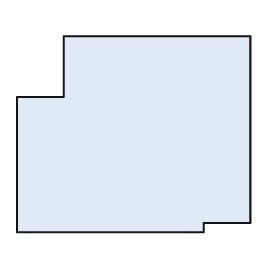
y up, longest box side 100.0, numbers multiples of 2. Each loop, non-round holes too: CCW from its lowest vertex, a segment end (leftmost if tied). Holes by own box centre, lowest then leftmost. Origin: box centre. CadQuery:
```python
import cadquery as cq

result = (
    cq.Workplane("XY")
    .moveTo(-50.0, -42.0)
    .lineTo(30.0, -42.0)
    .lineTo(30.0, -38.0)
    .lineTo(50.0, -38.0)
    .lineTo(50.0, 42.0)
    .lineTo(-30.0, 42.0)
    .lineTo(-30.0, 16.0)
    .lineTo(-50.0, 16.0)
    .close()
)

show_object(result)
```